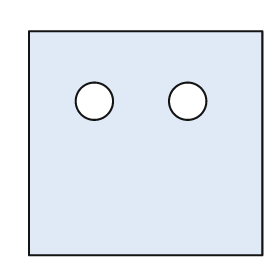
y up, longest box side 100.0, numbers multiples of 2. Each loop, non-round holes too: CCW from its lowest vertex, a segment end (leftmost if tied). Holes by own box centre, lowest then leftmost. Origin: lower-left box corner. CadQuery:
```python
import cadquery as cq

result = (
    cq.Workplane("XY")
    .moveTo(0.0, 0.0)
    .lineTo(100.0, 0.0)
    .lineTo(100.0, 96.0)
    .lineTo(0.0, 96.0)
    .close()
    .moveTo(28.0, 66.0)
    .circle(8.0)
    .moveTo(68.0, 66.0)
    .circle(8.0)
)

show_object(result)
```